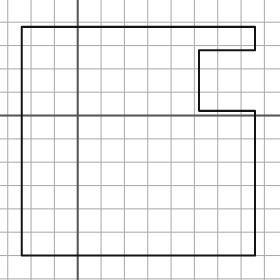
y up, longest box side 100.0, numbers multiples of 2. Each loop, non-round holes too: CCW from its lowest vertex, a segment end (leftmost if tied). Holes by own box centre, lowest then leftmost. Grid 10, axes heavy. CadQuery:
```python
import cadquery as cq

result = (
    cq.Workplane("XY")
    .moveTo(-24.0, -60.0)
    .lineTo(76.0, -60.0)
    .lineTo(76.0, 2.0)
    .lineTo(52.0, 2.0)
    .lineTo(52.0, 28.0)
    .lineTo(76.0, 28.0)
    .lineTo(76.0, 38.0)
    .lineTo(-24.0, 38.0)
    .close()
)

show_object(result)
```